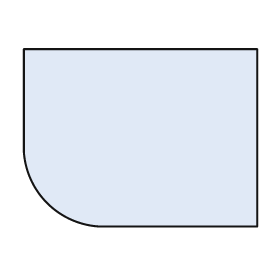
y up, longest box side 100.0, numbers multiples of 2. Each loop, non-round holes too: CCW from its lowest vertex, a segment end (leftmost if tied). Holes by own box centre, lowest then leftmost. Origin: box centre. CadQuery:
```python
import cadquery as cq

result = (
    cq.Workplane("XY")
    .moveTo(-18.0, -38.0)
    .lineTo(50.0, -38.0)
    .lineTo(50.0, 38.0)
    .lineTo(-50.0, 38.0)
    .lineTo(-50.0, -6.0)
    .threePointArc((-40.0, -28.0), (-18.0, -38.0))
    .close()
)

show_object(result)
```